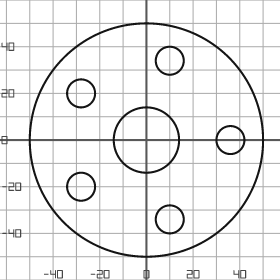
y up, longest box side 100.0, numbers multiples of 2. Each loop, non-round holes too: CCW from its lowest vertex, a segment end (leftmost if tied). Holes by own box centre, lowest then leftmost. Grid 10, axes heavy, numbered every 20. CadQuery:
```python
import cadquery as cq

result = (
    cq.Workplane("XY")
    .moveTo(0.0, 0.0)
    .circle(50.0)
    .moveTo(10.0, -34.0)
    .circle(6.0)
    .moveTo(-28.0, -20.0)
    .circle(6.0)
    .moveTo(0.0, 0.0)
    .circle(14.0)
    .moveTo(36.0, 0.0)
    .circle(6.0)
    .moveTo(-28.0, 20.0)
    .circle(6.0)
    .moveTo(10.0, 34.0)
    .circle(6.0)
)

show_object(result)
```